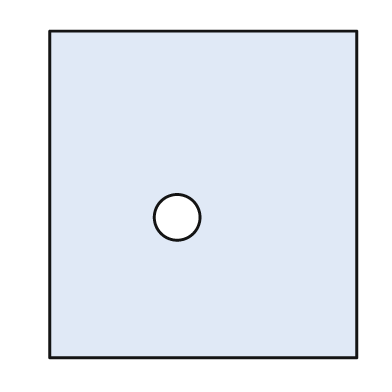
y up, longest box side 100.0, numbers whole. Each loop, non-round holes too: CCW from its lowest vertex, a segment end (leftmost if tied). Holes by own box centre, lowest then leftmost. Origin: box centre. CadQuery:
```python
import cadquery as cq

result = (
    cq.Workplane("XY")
    .moveTo(-47.0, -50.0)
    .lineTo(47.0, -50.0)
    .lineTo(47.0, 50.0)
    .lineTo(-47.0, 50.0)
    .close()
    .moveTo(-8.0, -7.0)
    .circle(7.0)
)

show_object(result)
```